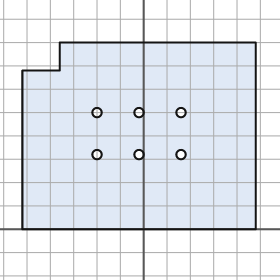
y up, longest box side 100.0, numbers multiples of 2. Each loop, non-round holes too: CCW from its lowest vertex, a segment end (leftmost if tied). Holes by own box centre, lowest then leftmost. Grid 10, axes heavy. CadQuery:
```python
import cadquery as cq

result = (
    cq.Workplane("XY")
    .moveTo(-52.0, 0.0)
    .lineTo(48.0, 0.0)
    .lineTo(48.0, 80.0)
    .lineTo(-36.0, 80.0)
    .lineTo(-36.0, 68.0)
    .lineTo(-52.0, 68.0)
    .close()
    .moveTo(-20.0, 32.0)
    .circle(2.0)
    .moveTo(-2.0, 32.0)
    .circle(2.0)
    .moveTo(16.0, 32.0)
    .circle(2.0)
    .moveTo(-20.0, 50.0)
    .circle(2.0)
    .moveTo(-2.0, 50.0)
    .circle(2.0)
    .moveTo(16.0, 50.0)
    .circle(2.0)
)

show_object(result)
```